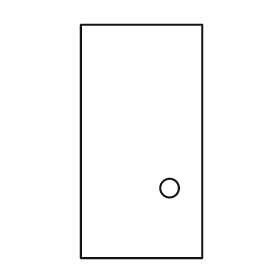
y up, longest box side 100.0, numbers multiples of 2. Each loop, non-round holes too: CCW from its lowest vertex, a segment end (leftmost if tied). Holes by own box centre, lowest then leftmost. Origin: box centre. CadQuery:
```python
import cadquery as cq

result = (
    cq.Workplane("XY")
    .moveTo(-26.0, -50.0)
    .lineTo(26.0, -50.0)
    .lineTo(26.0, 50.0)
    .lineTo(-26.0, 50.0)
    .close()
    .moveTo(12.0, -20.0)
    .circle(4.0)
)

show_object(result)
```